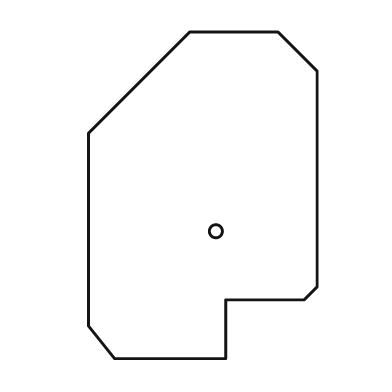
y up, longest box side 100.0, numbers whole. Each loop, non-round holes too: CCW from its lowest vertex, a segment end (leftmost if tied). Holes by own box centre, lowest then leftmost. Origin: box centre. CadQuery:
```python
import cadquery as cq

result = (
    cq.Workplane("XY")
    .moveTo(-27.0, -50.0)
    .lineTo(7.0, -50.0)
    .lineTo(7.0, -32.0)
    .lineTo(31.0, -32.0)
    .lineTo(35.0, -28.0)
    .lineTo(35.0, 38.0)
    .lineTo(23.0, 50.0)
    .lineTo(-4.0, 50.0)
    .lineTo(-35.0, 19.0)
    .lineTo(-35.0, -40.0)
    .close()
    .moveTo(4.0, -11.0)
    .circle(2.0)
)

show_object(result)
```